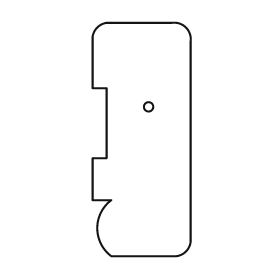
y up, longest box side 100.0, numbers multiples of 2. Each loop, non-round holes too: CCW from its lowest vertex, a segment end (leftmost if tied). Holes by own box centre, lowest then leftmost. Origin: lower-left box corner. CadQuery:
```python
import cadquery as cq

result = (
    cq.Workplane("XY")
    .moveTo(8.0, 0.0)
    .lineTo(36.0, 0.0)
    .threePointArc((40.0, 2.0), (42.0, 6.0))
    .lineTo(42.0, 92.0)
    .threePointArc((40.0, 98.0), (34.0, 100.0))
    .lineTo(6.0, 100.0)
    .threePointArc((2.0, 98.0), (0.0, 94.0))
    .lineTo(0.0, 72.0)
    .lineTo(6.0, 72.0)
    .lineTo(6.0, 42.0)
    .lineTo(0.0, 42.0)
    .lineTo(0.0, 24.0)
    .lineTo(8.0, 24.0)
    .threePointArc((2.0, 12.0), (8.0, 0.0))
    .close()
    .moveTo(24.0, 64.0)
    .circle(2.0)
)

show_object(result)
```